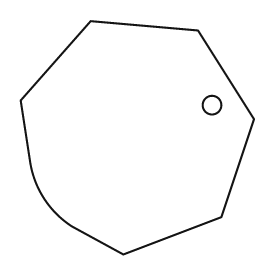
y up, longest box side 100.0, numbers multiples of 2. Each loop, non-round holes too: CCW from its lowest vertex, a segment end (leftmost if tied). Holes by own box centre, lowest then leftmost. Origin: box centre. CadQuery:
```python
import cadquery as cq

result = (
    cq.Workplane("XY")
    .moveTo(-6.0, -50.0)
    .lineTo(36.0, -34.0)
    .lineTo(50.0, 8.0)
    .lineTo(26.0, 46.0)
    .lineTo(-20.0, 50.0)
    .lineTo(-50.0, 16.0)
    .lineTo(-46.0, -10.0)
    .threePointArc((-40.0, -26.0), (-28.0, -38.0))
    .close()
    .moveTo(32.0, 14.0)
    .circle(4.0)
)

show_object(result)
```